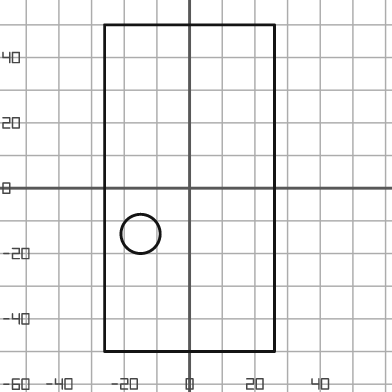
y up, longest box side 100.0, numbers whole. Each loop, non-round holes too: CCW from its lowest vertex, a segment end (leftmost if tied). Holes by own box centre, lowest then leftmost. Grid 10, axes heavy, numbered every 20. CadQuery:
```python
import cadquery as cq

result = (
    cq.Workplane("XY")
    .moveTo(-26.0, -50.0)
    .lineTo(26.0, -50.0)
    .lineTo(26.0, 50.0)
    .lineTo(-26.0, 50.0)
    .close()
    .moveTo(-15.0, -14.0)
    .circle(6.0)
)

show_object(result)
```